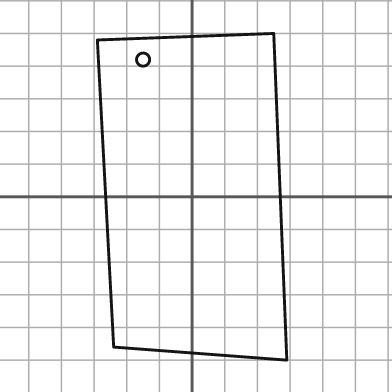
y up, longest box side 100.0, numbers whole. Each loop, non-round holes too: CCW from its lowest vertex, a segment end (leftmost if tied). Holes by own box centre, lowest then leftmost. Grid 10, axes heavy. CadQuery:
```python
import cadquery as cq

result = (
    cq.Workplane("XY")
    .moveTo(29.0, -50.0)
    .lineTo(25.0, 50.0)
    .lineTo(-29.0, 48.0)
    .lineTo(-24.0, -46.0)
    .close()
    .moveTo(-15.0, 42.0)
    .circle(2.0)
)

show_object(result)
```